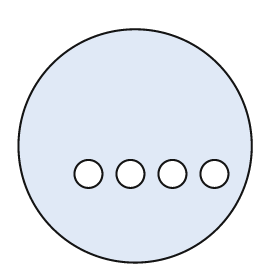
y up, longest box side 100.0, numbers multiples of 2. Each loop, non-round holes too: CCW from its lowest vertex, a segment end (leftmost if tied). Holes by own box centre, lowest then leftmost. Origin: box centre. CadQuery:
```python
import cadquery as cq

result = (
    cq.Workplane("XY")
    .moveTo(0.0, 0.0)
    .circle(50.0)
    .moveTo(-20.0, -12.0)
    .circle(6.0)
    .moveTo(-2.0, -12.0)
    .circle(6.0)
    .moveTo(16.0, -12.0)
    .circle(6.0)
    .moveTo(34.0, -12.0)
    .circle(6.0)
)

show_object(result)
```